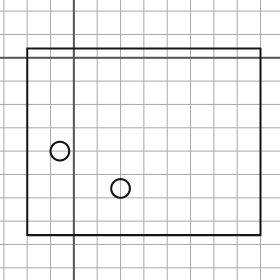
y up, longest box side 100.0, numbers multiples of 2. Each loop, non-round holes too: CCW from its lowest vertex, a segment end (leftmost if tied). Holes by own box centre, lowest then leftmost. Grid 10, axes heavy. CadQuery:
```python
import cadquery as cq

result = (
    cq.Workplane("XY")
    .moveTo(-20.0, -76.0)
    .lineTo(80.0, -76.0)
    .lineTo(80.0, 4.0)
    .lineTo(-20.0, 4.0)
    .close()
    .moveTo(20.0, -56.0)
    .circle(4.0)
    .moveTo(-6.0, -40.0)
    .circle(4.0)
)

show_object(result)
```